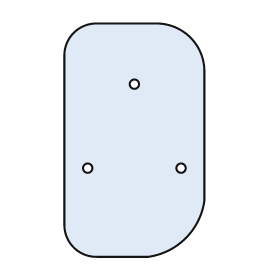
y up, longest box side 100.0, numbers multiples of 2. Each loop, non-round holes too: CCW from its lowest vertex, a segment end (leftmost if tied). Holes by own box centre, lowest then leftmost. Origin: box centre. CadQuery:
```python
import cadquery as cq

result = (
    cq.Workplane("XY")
    .moveTo(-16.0, -50.0)
    .lineTo(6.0, -50.0)
    .threePointArc((22.0, -42.0), (30.0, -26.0))
    .lineTo(30.0, 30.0)
    .threePointArc((24.0, 44.0), (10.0, 50.0))
    .lineTo(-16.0, 50.0)
    .threePointArc((-26.0, 46.0), (-30.0, 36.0))
    .lineTo(-30.0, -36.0)
    .threePointArc((-26.0, -46.0), (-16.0, -50.0))
    .close()
    .moveTo(-20.0, -12.0)
    .circle(2.0)
    .moveTo(20.0, -12.0)
    .circle(2.0)
    .moveTo(0.0, 24.0)
    .circle(2.0)
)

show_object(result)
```